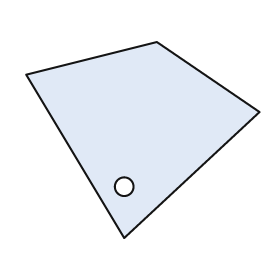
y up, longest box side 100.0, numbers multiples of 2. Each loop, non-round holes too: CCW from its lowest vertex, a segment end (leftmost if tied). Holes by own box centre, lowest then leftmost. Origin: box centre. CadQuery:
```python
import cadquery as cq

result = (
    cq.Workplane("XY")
    .moveTo(-8.0, -42.0)
    .lineTo(50.0, 12.0)
    .lineTo(6.0, 42.0)
    .lineTo(-50.0, 28.0)
    .close()
    .moveTo(-8.0, -20.0)
    .circle(4.0)
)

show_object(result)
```